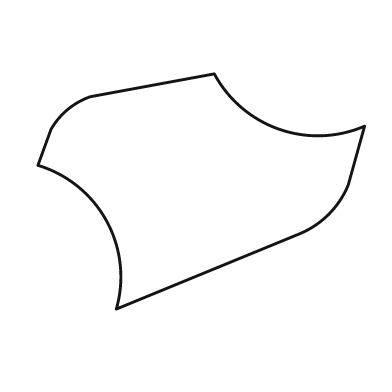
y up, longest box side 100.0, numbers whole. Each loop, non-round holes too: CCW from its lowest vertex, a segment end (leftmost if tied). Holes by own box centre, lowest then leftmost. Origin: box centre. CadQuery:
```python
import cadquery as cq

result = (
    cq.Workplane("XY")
    .moveTo(-26.0, -36.0)
    .lineTo(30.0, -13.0)
    .threePointArc((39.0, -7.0), (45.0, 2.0))
    .lineTo(50.0, 20.0)
    .threePointArc((24.0, 19.0), (4.0, 36.0))
    .lineTo(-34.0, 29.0)
    .threePointArc((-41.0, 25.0), (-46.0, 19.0))
    .lineTo(-50.0, 8.0)
    .threePointArc((-29.0, -9.0), (-26.0, -36.0))
    .close()
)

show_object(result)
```